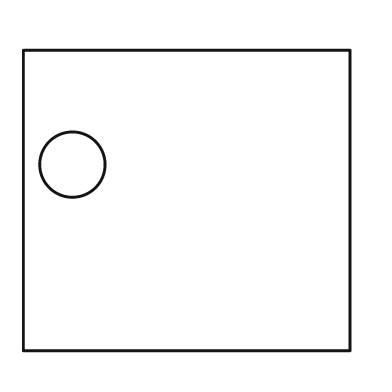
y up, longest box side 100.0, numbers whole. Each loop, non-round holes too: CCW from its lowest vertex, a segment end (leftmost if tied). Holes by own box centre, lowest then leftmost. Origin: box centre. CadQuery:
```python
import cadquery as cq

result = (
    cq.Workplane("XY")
    .moveTo(-50.0, -46.0)
    .lineTo(50.0, -46.0)
    .lineTo(50.0, 46.0)
    .lineTo(-50.0, 46.0)
    .close()
    .moveTo(-35.0, 11.0)
    .circle(10.0)
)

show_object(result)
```